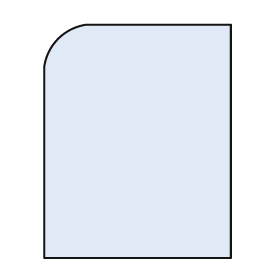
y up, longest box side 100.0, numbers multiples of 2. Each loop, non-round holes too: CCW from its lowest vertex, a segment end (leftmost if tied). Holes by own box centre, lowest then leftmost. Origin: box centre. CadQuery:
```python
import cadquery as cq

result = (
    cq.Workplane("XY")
    .moveTo(-40.0, -50.0)
    .lineTo(40.0, -50.0)
    .lineTo(40.0, 50.0)
    .lineTo(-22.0, 50.0)
    .threePointArc((-34.0, 44.0), (-40.0, 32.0))
    .close()
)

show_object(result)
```